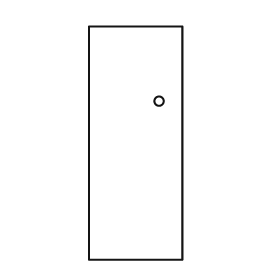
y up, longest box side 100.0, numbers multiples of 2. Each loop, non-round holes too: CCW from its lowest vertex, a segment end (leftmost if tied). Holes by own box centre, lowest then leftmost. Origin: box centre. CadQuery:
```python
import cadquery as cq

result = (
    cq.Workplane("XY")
    .moveTo(-20.0, -50.0)
    .lineTo(20.0, -50.0)
    .lineTo(20.0, 50.0)
    .lineTo(-20.0, 50.0)
    .close()
    .moveTo(10.0, 18.0)
    .circle(2.0)
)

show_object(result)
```